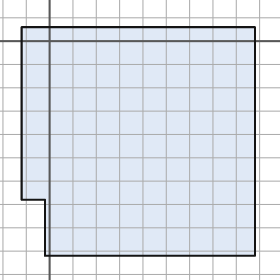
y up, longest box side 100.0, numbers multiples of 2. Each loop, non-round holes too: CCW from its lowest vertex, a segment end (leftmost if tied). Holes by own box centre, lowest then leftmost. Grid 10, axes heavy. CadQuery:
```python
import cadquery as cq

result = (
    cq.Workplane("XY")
    .moveTo(-2.0, -92.0)
    .lineTo(88.0, -92.0)
    .lineTo(88.0, 6.0)
    .lineTo(-12.0, 6.0)
    .lineTo(-12.0, -68.0)
    .lineTo(-2.0, -68.0)
    .close()
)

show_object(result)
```